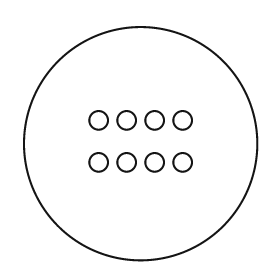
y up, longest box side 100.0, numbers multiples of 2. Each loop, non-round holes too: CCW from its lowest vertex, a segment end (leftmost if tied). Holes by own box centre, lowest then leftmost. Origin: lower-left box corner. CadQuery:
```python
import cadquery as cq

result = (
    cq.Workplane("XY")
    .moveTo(50.0, 50.0)
    .circle(50.0)
    .moveTo(32.0, 42.0)
    .circle(4.0)
    .moveTo(44.0, 42.0)
    .circle(4.0)
    .moveTo(56.0, 42.0)
    .circle(4.0)
    .moveTo(68.0, 42.0)
    .circle(4.0)
    .moveTo(32.0, 60.0)
    .circle(4.0)
    .moveTo(44.0, 60.0)
    .circle(4.0)
    .moveTo(56.0, 60.0)
    .circle(4.0)
    .moveTo(68.0, 60.0)
    .circle(4.0)
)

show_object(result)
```